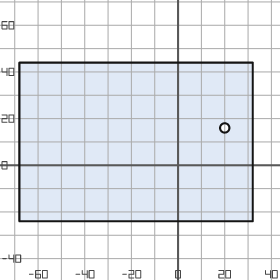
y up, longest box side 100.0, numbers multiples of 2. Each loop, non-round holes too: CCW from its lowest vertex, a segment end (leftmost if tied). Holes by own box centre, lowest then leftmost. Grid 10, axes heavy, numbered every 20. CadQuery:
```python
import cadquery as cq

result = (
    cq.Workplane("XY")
    .moveTo(-68.0, -24.0)
    .lineTo(32.0, -24.0)
    .lineTo(32.0, 44.0)
    .lineTo(-68.0, 44.0)
    .close()
    .moveTo(20.0, 16.0)
    .circle(2.0)
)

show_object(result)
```